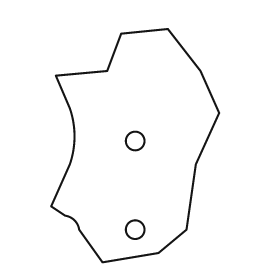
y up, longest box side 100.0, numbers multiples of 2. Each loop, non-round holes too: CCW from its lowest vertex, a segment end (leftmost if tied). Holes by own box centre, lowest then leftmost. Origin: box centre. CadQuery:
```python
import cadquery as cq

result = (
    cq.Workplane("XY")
    .moveTo(-14.0, -50.0)
    .lineTo(10.0, -46.0)
    .lineTo(22.0, -36.0)
    .lineTo(26.0, -8.0)
    .lineTo(36.0, 14.0)
    .lineTo(28.0, 32.0)
    .lineTo(14.0, 50.0)
    .lineTo(-6.0, 48.0)
    .lineTo(-12.0, 32.0)
    .lineTo(-34.0, 30.0)
    .lineTo(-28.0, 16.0)
    .threePointArc((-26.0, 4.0), (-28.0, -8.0))
    .lineTo(-36.0, -26.0)
    .lineTo(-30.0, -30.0)
    .threePointArc((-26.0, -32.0), (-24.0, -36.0))
    .close()
    .moveTo(0.0, -36.0)
    .circle(4.0)
    .moveTo(0.0, 2.0)
    .circle(4.0)
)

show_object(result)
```